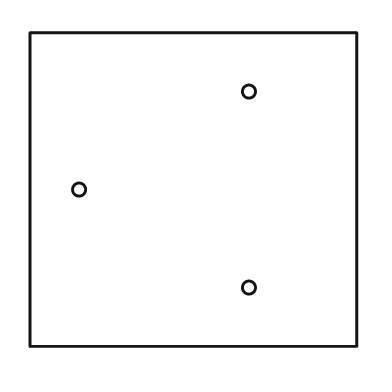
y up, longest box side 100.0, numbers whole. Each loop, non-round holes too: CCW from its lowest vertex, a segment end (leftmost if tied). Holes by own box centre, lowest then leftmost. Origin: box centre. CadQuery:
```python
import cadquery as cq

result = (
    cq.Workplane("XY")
    .moveTo(-50.0, -48.0)
    .lineTo(50.0, -48.0)
    .lineTo(50.0, 48.0)
    .lineTo(-50.0, 48.0)
    .close()
    .moveTo(17.0, -30.0)
    .circle(2.0)
    .moveTo(-35.0, 0.0)
    .circle(2.0)
    .moveTo(17.0, 30.0)
    .circle(2.0)
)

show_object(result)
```